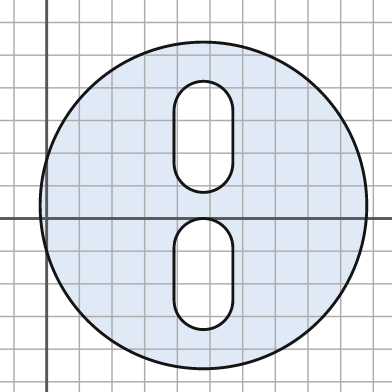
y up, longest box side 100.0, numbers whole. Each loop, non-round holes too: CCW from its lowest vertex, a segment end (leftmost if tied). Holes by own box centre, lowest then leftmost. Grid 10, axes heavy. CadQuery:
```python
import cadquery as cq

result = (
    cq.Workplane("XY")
    .moveTo(48.0, 4.0)
    .circle(50.0)
    .moveTo(39.0, -25.0)
    .threePointArc((48.0, -34.0), (57.0, -25.0))
    .lineTo(57.0, -9.0)
    .threePointArc((48.0, 0.0), (39.0, -9.0))
    .close()
    .moveTo(39.0, 17.0)
    .threePointArc((48.0, 8.0), (57.0, 17.0))
    .lineTo(57.0, 33.0)
    .threePointArc((48.0, 42.0), (39.0, 33.0))
    .close()
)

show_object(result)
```